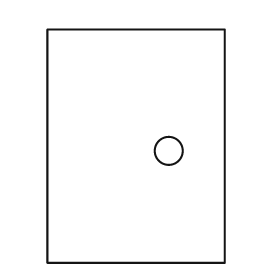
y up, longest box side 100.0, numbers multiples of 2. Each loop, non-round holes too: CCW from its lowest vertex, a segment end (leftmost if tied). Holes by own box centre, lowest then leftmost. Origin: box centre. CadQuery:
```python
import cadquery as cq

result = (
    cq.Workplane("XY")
    .moveTo(-38.0, -50.0)
    .lineTo(38.0, -50.0)
    .lineTo(38.0, 50.0)
    .lineTo(-38.0, 50.0)
    .close()
    .moveTo(14.0, -2.0)
    .circle(6.0)
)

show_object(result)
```